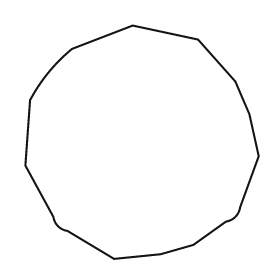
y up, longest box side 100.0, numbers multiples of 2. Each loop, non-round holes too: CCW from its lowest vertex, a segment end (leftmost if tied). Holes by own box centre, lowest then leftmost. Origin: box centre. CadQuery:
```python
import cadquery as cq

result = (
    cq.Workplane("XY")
    .moveTo(-12.0, -50.0)
    .lineTo(8.0, -48.0)
    .lineTo(22.0, -44.0)
    .lineTo(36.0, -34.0)
    .threePointArc((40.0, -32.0), (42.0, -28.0))
    .lineTo(50.0, -6.0)
    .lineTo(46.0, 12.0)
    .lineTo(40.0, 26.0)
    .lineTo(24.0, 44.0)
    .lineTo(-4.0, 50.0)
    .lineTo(-30.0, 40.0)
    .threePointArc((-40.0, 30.0), (-48.0, 18.0))
    .lineTo(-50.0, -10.0)
    .lineTo(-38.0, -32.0)
    .threePointArc((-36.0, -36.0), (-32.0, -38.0))
    .close()
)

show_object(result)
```